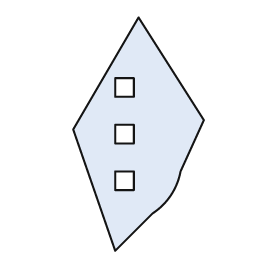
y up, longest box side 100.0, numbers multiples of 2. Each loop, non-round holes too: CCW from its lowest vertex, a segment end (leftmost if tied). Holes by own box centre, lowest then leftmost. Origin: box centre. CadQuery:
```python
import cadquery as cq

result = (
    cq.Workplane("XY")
    .moveTo(-10.0, -50.0)
    .lineTo(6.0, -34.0)
    .threePointArc((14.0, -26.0), (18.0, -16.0))
    .lineTo(28.0, 6.0)
    .lineTo(0.0, 50.0)
    .lineTo(-28.0, 2.0)
    .close()
    .moveTo(-10.0, -24.0)
    .lineTo(-2.0, -24.0)
    .lineTo(-2.0, -16.0)
    .lineTo(-10.0, -16.0)
    .close()
    .moveTo(-10.0, -4.0)
    .lineTo(-2.0, -4.0)
    .lineTo(-2.0, 4.0)
    .lineTo(-10.0, 4.0)
    .close()
    .moveTo(-10.0, 16.0)
    .lineTo(-2.0, 16.0)
    .lineTo(-2.0, 24.0)
    .lineTo(-10.0, 24.0)
    .close()
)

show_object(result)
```